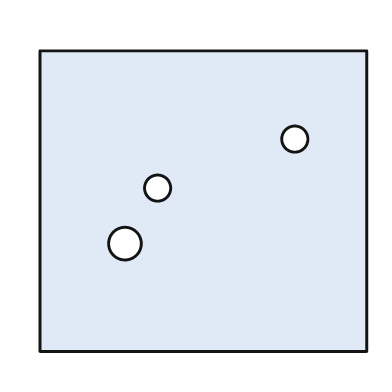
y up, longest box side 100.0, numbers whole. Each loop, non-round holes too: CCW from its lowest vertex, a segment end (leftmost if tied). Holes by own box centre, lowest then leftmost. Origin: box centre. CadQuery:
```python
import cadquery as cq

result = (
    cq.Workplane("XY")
    .moveTo(-50.0, -46.0)
    .lineTo(50.0, -46.0)
    .lineTo(50.0, 46.0)
    .lineTo(-50.0, 46.0)
    .close()
    .moveTo(-24.0, -13.0)
    .circle(5.0)
    .moveTo(-14.0, 4.0)
    .circle(4.0)
    .moveTo(28.0, 19.0)
    .circle(4.0)
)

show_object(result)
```